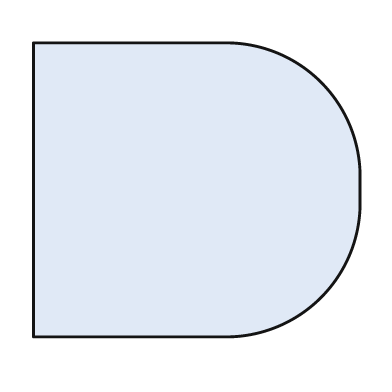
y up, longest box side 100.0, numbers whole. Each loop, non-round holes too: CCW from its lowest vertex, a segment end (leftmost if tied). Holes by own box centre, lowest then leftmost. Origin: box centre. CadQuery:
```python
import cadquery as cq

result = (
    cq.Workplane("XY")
    .moveTo(-50.0, -45.0)
    .lineTo(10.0, -45.0)
    .threePointArc((38.0, -33.0), (50.0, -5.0))
    .lineTo(50.0, 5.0)
    .threePointArc((38.0, 33.0), (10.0, 45.0))
    .lineTo(-50.0, 45.0)
    .close()
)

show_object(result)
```